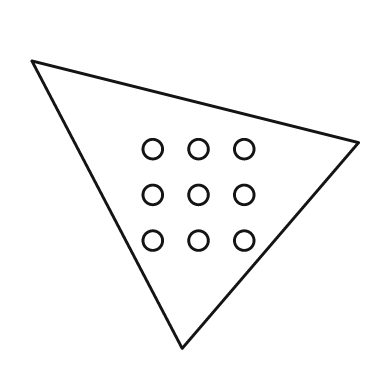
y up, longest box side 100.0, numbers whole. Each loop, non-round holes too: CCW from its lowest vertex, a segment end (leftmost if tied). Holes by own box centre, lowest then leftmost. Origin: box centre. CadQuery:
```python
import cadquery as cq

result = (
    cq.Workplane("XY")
    .moveTo(-4.0, -44.0)
    .lineTo(50.0, 19.0)
    .lineTo(-50.0, 44.0)
    .close()
    .moveTo(-13.0, -11.0)
    .circle(3.0)
    .moveTo(1.0, -11.0)
    .circle(3.0)
    .moveTo(15.0, -11.0)
    .circle(3.0)
    .moveTo(-13.0, 3.0)
    .circle(3.0)
    .moveTo(1.0, 3.0)
    .circle(3.0)
    .moveTo(15.0, 3.0)
    .circle(3.0)
    .moveTo(-13.0, 17.0)
    .circle(3.0)
    .moveTo(1.0, 17.0)
    .circle(3.0)
    .moveTo(15.0, 17.0)
    .circle(3.0)
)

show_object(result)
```